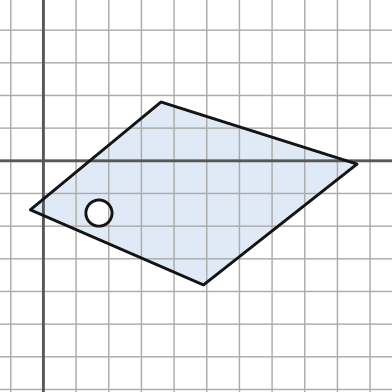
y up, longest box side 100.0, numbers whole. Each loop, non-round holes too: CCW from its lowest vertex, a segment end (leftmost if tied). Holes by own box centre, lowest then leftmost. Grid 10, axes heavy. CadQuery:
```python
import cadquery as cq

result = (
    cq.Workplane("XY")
    .moveTo(49.0, -38.0)
    .lineTo(96.0, -1.0)
    .lineTo(36.0, 18.0)
    .lineTo(-4.0, -15.0)
    .close()
    .moveTo(17.0, -16.0)
    .circle(4.0)
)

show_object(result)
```